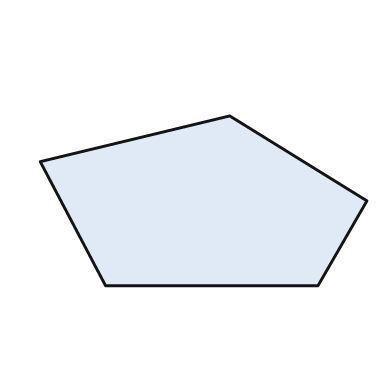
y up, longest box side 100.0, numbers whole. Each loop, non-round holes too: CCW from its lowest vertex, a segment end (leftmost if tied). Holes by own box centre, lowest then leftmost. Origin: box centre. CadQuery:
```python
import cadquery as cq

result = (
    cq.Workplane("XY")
    .moveTo(-30.0, -26.0)
    .lineTo(35.0, -26.0)
    .lineTo(50.0, 0.0)
    .lineTo(8.0, 26.0)
    .lineTo(-50.0, 12.0)
    .close()
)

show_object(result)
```